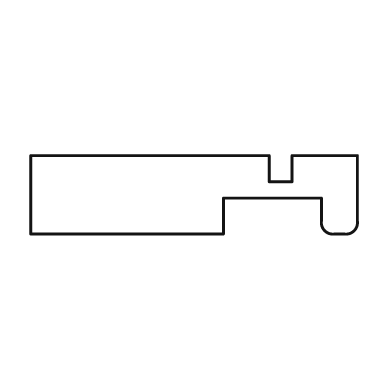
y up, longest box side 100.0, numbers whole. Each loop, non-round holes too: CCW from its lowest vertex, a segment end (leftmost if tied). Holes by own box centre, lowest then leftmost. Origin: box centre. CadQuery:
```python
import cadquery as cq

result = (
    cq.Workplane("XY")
    .moveTo(-50.0, -12.0)
    .lineTo(9.0, -12.0)
    .lineTo(9.0, -1.0)
    .lineTo(39.0, -1.0)
    .lineTo(39.0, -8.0)
    .threePointArc((40.0, -11.0), (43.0, -12.0))
    .lineTo(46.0, -12.0)
    .threePointArc((49.0, -11.0), (50.0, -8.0))
    .lineTo(50.0, 12.0)
    .lineTo(30.0, 12.0)
    .lineTo(30.0, 4.0)
    .lineTo(23.0, 4.0)
    .lineTo(23.0, 12.0)
    .lineTo(-50.0, 12.0)
    .close()
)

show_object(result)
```